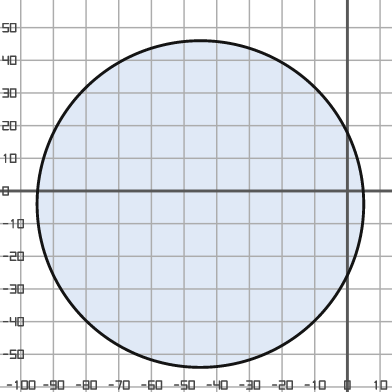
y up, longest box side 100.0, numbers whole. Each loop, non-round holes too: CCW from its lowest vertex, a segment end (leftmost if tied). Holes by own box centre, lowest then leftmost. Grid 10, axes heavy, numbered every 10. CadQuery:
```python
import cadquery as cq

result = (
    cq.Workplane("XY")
    .moveTo(-45.0, -4.0)
    .circle(50.0)
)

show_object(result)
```